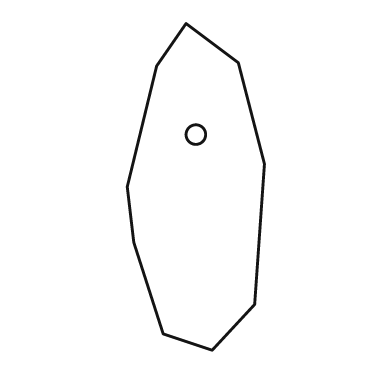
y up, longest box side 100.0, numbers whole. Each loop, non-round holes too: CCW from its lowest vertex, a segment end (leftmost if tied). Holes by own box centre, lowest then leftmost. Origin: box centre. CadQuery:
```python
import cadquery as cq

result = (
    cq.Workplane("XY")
    .moveTo(5.0, -50.0)
    .lineTo(18.0, -36.0)
    .lineTo(21.0, 7.0)
    .lineTo(13.0, 38.0)
    .lineTo(-3.0, 50.0)
    .lineTo(-12.0, 37.0)
    .lineTo(-21.0, 0.0)
    .lineTo(-19.0, -17.0)
    .lineTo(-10.0, -45.0)
    .close()
    .moveTo(0.0, 16.0)
    .circle(3.0)
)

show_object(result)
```